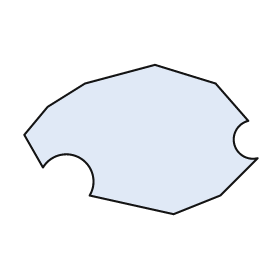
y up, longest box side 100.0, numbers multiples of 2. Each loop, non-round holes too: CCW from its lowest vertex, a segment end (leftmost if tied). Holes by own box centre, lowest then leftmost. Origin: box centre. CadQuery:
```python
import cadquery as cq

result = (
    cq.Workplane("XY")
    .moveTo(14.0, -32.0)
    .lineTo(34.0, -24.0)
    .lineTo(50.0, -8.0)
    .threePointArc((40.0, -2.0), (46.0, 8.0))
    .lineTo(32.0, 24.0)
    .lineTo(6.0, 32.0)
    .lineTo(-24.0, 24.0)
    .lineTo(-40.0, 14.0)
    .lineTo(-50.0, 2.0)
    .lineTo(-42.0, -12.0)
    .threePointArc((-26.0, -8.0), (-22.0, -24.0))
    .close()
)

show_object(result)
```